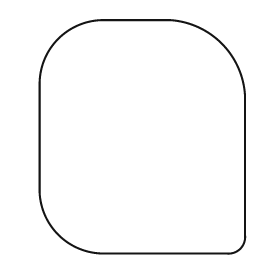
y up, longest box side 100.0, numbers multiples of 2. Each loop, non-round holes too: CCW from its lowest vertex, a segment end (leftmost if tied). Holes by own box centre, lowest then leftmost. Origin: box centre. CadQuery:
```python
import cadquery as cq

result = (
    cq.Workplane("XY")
    .moveTo(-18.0, -50.0)
    .lineTo(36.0, -50.0)
    .threePointArc((42.0, -48.0), (44.0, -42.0))
    .lineTo(44.0, 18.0)
    .threePointArc((34.0, 40.0), (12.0, 50.0))
    .lineTo(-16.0, 50.0)
    .threePointArc((-36.0, 42.0), (-44.0, 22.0))
    .lineTo(-44.0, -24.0)
    .threePointArc((-36.0, -42.0), (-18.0, -50.0))
    .close()
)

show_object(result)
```